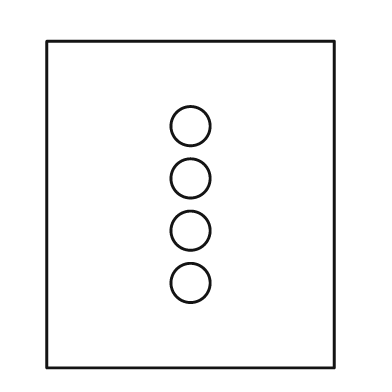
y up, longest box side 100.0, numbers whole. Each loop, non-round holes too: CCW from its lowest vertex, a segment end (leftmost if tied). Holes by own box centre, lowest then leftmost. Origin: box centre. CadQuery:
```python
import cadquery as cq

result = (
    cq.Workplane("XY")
    .moveTo(-44.0, -50.0)
    .lineTo(44.0, -50.0)
    .lineTo(44.0, 50.0)
    .lineTo(-44.0, 50.0)
    .close()
    .moveTo(0.0, -24.0)
    .circle(6.0)
    .moveTo(0.0, -8.0)
    .circle(6.0)
    .moveTo(0.0, 8.0)
    .circle(6.0)
    .moveTo(0.0, 24.0)
    .circle(6.0)
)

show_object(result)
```